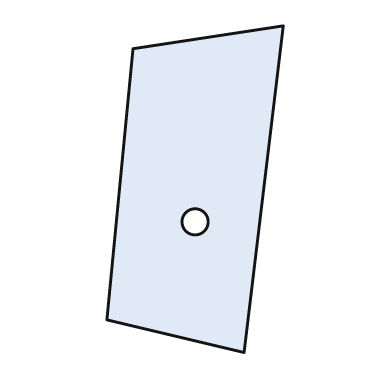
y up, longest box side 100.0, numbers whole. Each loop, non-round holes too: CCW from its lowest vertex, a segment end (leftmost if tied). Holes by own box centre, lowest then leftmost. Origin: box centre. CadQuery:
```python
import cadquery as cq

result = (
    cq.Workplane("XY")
    .moveTo(15.0, -50.0)
    .lineTo(27.0, 50.0)
    .lineTo(-19.0, 43.0)
    .lineTo(-27.0, -40.0)
    .close()
    .moveTo(0.0, -10.0)
    .circle(4.0)
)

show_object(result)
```